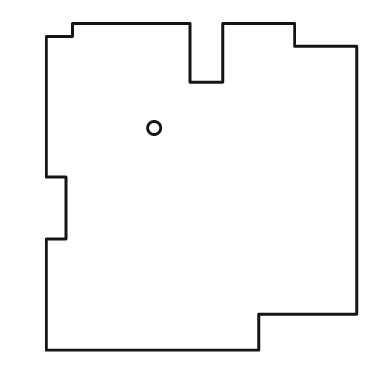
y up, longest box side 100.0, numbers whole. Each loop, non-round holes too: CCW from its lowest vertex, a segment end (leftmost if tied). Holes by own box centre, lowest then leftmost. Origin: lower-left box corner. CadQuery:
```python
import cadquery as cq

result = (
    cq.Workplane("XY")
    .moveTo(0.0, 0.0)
    .lineTo(65.0, 0.0)
    .lineTo(65.0, 11.0)
    .lineTo(95.0, 11.0)
    .lineTo(95.0, 93.0)
    .lineTo(76.0, 93.0)
    .lineTo(76.0, 100.0)
    .lineTo(54.0, 100.0)
    .lineTo(54.0, 82.0)
    .lineTo(44.0, 82.0)
    .lineTo(44.0, 100.0)
    .lineTo(8.0, 100.0)
    .lineTo(8.0, 96.0)
    .lineTo(0.0, 96.0)
    .lineTo(0.0, 53.0)
    .lineTo(6.0, 53.0)
    .lineTo(6.0, 34.0)
    .lineTo(0.0, 34.0)
    .close()
    .moveTo(33.0, 68.0)
    .circle(2.0)
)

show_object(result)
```